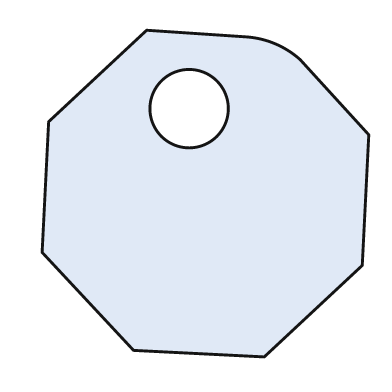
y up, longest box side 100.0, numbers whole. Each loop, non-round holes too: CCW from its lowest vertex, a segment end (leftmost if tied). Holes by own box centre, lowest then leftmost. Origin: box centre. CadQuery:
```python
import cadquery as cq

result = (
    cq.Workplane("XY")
    .moveTo(18.0, -50.0)
    .lineTo(48.0, -22.0)
    .lineTo(50.0, 18.0)
    .lineTo(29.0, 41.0)
    .threePointArc((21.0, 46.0), (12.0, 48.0))
    .lineTo(-18.0, 50.0)
    .lineTo(-48.0, 22.0)
    .lineTo(-50.0, -18.0)
    .lineTo(-22.0, -48.0)
    .close()
    .moveTo(-5.0, 26.0)
    .circle(12.0)
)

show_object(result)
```